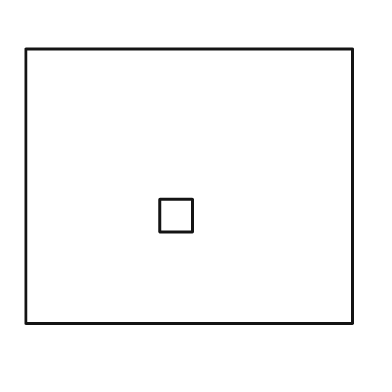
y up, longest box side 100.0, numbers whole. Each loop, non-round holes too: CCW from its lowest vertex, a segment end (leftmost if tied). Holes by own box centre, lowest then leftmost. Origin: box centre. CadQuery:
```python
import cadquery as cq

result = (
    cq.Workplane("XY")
    .moveTo(-50.0, -42.0)
    .lineTo(50.0, -42.0)
    .lineTo(50.0, 42.0)
    .lineTo(-50.0, 42.0)
    .close()
    .moveTo(-9.0, -14.0)
    .lineTo(1.0, -14.0)
    .lineTo(1.0, -4.0)
    .lineTo(-9.0, -4.0)
    .close()
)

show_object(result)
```